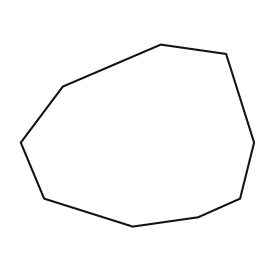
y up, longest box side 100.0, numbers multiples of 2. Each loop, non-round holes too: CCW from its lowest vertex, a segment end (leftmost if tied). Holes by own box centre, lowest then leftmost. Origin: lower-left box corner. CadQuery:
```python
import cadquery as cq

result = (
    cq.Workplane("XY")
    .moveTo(48.0, 0.0)
    .lineTo(76.0, 4.0)
    .lineTo(94.0, 12.0)
    .lineTo(100.0, 36.0)
    .lineTo(88.0, 74.0)
    .lineTo(60.0, 78.0)
    .lineTo(18.0, 60.0)
    .lineTo(0.0, 36.0)
    .lineTo(10.0, 12.0)
    .close()
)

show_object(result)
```